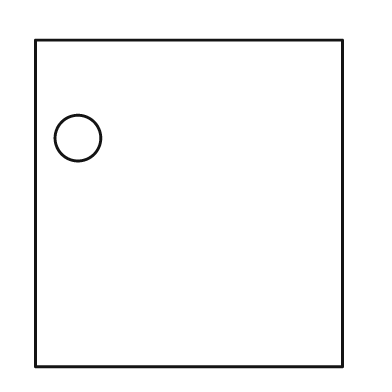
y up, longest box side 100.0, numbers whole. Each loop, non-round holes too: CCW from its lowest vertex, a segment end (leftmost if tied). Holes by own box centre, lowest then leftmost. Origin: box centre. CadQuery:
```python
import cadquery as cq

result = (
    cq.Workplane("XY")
    .moveTo(-47.0, -50.0)
    .lineTo(47.0, -50.0)
    .lineTo(47.0, 50.0)
    .lineTo(-47.0, 50.0)
    .close()
    .moveTo(-34.0, 20.0)
    .circle(7.0)
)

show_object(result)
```